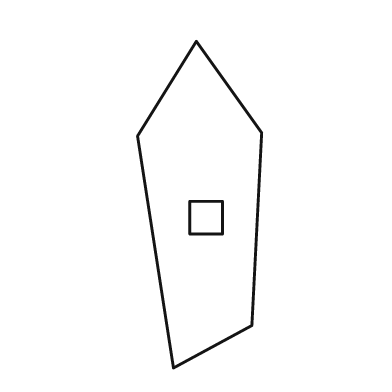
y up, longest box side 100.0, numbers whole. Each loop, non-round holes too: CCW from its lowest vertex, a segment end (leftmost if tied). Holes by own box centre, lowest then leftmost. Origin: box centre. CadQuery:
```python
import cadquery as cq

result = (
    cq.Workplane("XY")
    .moveTo(-8.0, -50.0)
    .lineTo(16.0, -37.0)
    .lineTo(19.0, 22.0)
    .lineTo(-1.0, 50.0)
    .lineTo(-19.0, 21.0)
    .close()
    .moveTo(-3.0, -9.0)
    .lineTo(7.0, -9.0)
    .lineTo(7.0, 1.0)
    .lineTo(-3.0, 1.0)
    .close()
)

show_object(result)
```